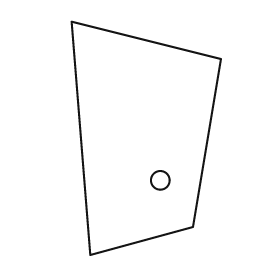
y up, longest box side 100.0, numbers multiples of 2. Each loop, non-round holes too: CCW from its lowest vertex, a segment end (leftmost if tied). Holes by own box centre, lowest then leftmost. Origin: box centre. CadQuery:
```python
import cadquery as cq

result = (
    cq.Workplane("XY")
    .moveTo(-24.0, -50.0)
    .lineTo(20.0, -38.0)
    .lineTo(32.0, 34.0)
    .lineTo(-32.0, 50.0)
    .close()
    .moveTo(6.0, -18.0)
    .circle(4.0)
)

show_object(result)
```